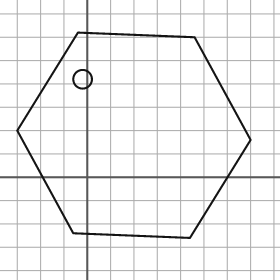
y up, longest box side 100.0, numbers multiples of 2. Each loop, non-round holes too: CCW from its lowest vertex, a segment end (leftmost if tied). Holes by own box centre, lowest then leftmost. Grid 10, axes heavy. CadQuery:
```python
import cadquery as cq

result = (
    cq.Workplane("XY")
    .moveTo(44.0, -26.0)
    .lineTo(70.0, 16.0)
    .lineTo(46.0, 60.0)
    .lineTo(-4.0, 62.0)
    .lineTo(-30.0, 20.0)
    .lineTo(-6.0, -24.0)
    .close()
    .moveTo(-2.0, 42.0)
    .circle(4.0)
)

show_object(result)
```